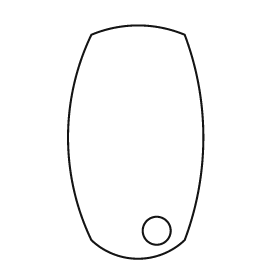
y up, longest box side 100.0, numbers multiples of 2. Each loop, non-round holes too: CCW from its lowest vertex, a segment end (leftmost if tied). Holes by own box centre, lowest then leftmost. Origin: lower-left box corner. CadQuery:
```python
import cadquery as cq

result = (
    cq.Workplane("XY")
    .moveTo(10.0, 8.0)
    .threePointArc((30.0, 0.0), (50.0, 8.0))
    .threePointArc((58.0, 52.0), (50.0, 96.0))
    .threePointArc((30.0, 100.0), (10.0, 96.0))
    .threePointArc((0.0, 52.0), (10.0, 8.0))
    .close()
    .moveTo(38.0, 12.0)
    .circle(6.0)
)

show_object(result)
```